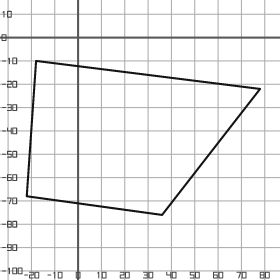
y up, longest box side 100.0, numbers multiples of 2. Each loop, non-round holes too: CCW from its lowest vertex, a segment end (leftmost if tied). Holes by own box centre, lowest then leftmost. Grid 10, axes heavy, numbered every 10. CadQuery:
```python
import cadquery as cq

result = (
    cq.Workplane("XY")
    .moveTo(36.0, -76.0)
    .lineTo(78.0, -22.0)
    .lineTo(-18.0, -10.0)
    .lineTo(-22.0, -68.0)
    .close()
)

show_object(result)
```